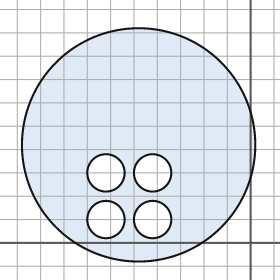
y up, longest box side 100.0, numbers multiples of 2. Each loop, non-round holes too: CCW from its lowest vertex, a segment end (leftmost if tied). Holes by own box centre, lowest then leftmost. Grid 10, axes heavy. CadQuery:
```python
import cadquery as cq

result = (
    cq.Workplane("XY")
    .moveTo(-48.0, 42.0)
    .circle(50.0)
    .moveTo(-62.0, 10.0)
    .circle(8.0)
    .moveTo(-42.0, 10.0)
    .circle(8.0)
    .moveTo(-62.0, 30.0)
    .circle(8.0)
    .moveTo(-42.0, 30.0)
    .circle(8.0)
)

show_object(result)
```